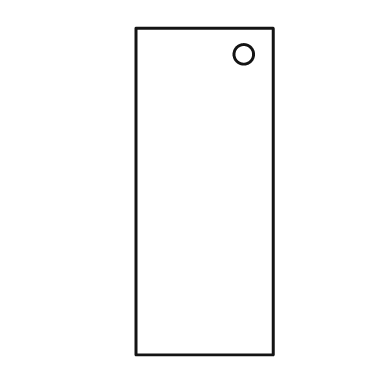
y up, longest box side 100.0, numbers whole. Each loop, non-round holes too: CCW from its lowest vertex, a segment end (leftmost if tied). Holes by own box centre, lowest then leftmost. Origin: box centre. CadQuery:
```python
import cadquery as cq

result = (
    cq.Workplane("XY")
    .moveTo(-21.0, -50.0)
    .lineTo(21.0, -50.0)
    .lineTo(21.0, 50.0)
    .lineTo(-21.0, 50.0)
    .close()
    .moveTo(12.0, 42.0)
    .circle(3.0)
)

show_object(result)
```